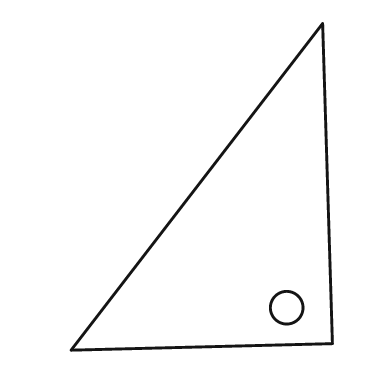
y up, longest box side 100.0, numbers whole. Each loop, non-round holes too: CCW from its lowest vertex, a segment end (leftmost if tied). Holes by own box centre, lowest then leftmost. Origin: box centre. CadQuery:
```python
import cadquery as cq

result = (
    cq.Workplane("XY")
    .moveTo(-40.0, -50.0)
    .lineTo(40.0, -48.0)
    .lineTo(37.0, 50.0)
    .close()
    .moveTo(26.0, -37.0)
    .circle(5.0)
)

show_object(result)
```